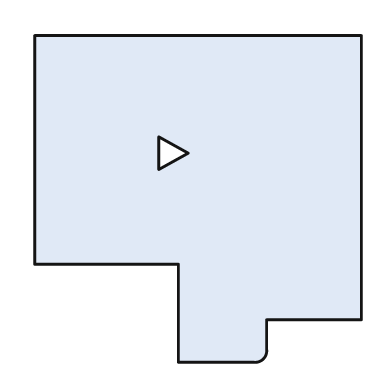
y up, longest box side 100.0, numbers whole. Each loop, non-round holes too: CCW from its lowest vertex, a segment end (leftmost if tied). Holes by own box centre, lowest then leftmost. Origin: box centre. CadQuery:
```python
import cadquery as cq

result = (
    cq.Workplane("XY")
    .moveTo(-6.0, -50.0)
    .lineTo(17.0, -50.0)
    .threePointArc((20.0, -49.0), (21.0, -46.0))
    .lineTo(21.0, -37.0)
    .lineTo(50.0, -37.0)
    .lineTo(50.0, 50.0)
    .lineTo(-50.0, 50.0)
    .lineTo(-50.0, -20.0)
    .lineTo(-6.0, -20.0)
    .close()
    .moveTo(-12.0, 9.0)
    .lineTo(-3.0, 14.0)
    .lineTo(-12.0, 19.0)
    .close()
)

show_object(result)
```